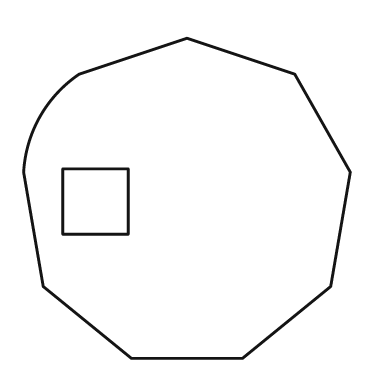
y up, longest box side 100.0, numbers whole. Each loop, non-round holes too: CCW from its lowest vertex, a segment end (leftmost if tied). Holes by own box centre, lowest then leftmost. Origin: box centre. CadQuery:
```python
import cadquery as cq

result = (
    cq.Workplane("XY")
    .moveTo(-17.0, -49.0)
    .lineTo(17.0, -49.0)
    .lineTo(44.0, -27.0)
    .lineTo(50.0, 8.0)
    .lineTo(33.0, 38.0)
    .lineTo(0.0, 49.0)
    .lineTo(-33.0, 38.0)
    .threePointArc((-45.0, 25.0), (-50.0, 8.0))
    .lineTo(-44.0, -27.0)
    .close()
    .moveTo(-38.0, -11.0)
    .lineTo(-18.0, -11.0)
    .lineTo(-18.0, 9.0)
    .lineTo(-38.0, 9.0)
    .close()
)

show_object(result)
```